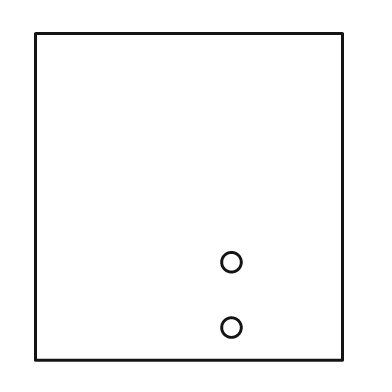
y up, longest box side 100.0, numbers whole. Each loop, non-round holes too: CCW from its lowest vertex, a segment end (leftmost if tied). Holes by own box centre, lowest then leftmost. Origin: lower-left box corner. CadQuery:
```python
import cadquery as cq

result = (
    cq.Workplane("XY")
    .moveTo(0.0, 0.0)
    .lineTo(94.0, 0.0)
    .lineTo(94.0, 100.0)
    .lineTo(0.0, 100.0)
    .close()
    .moveTo(60.0, 10.0)
    .circle(3.0)
    .moveTo(60.0, 30.0)
    .circle(3.0)
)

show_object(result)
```